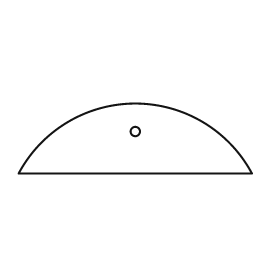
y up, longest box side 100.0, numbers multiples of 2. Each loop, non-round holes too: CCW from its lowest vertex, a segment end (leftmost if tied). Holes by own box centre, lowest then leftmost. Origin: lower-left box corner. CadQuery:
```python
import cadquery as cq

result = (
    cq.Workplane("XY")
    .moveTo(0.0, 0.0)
    .lineTo(100.0, 0.0)
    .threePointArc((50.0, 30.0), (0.0, 0.0))
    .close()
    .moveTo(50.0, 18.0)
    .circle(2.0)
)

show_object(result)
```